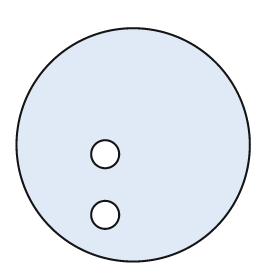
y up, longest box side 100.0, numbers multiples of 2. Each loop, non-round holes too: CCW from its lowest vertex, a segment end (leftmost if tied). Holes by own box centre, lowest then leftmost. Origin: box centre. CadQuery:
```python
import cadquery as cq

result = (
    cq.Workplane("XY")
    .moveTo(0.0, 0.0)
    .circle(50.0)
    .moveTo(-12.0, -30.0)
    .circle(6.0)
    .moveTo(-12.0, -4.0)
    .circle(6.0)
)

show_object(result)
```